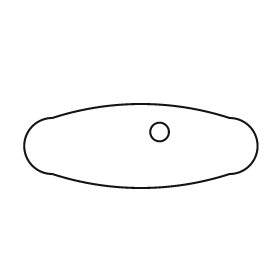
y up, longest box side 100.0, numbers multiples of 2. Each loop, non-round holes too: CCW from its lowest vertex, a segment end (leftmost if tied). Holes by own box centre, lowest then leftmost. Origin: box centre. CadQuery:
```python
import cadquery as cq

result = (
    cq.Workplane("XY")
    .moveTo(-38.0, -12.0)
    .threePointArc((0.0, -18.0), (38.0, -12.0))
    .threePointArc((50.0, 0.0), (38.0, 12.0))
    .threePointArc((0.0, 18.0), (-38.0, 12.0))
    .threePointArc((-50.0, 0.0), (-38.0, -12.0))
    .close()
    .moveTo(8.0, 6.0)
    .circle(4.0)
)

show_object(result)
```